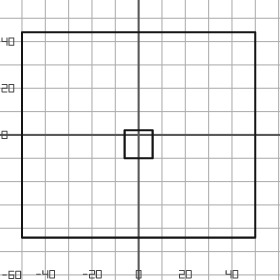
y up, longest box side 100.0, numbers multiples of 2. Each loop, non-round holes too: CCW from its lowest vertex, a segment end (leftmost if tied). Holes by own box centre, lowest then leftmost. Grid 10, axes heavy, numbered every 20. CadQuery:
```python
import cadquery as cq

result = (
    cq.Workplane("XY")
    .moveTo(-50.0, -44.0)
    .lineTo(50.0, -44.0)
    .lineTo(50.0, 44.0)
    .lineTo(-50.0, 44.0)
    .close()
    .moveTo(-6.0, -10.0)
    .lineTo(6.0, -10.0)
    .lineTo(6.0, 2.0)
    .lineTo(-6.0, 2.0)
    .close()
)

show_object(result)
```